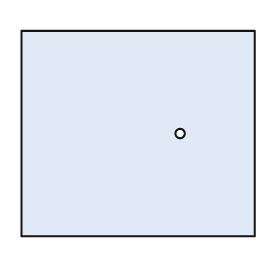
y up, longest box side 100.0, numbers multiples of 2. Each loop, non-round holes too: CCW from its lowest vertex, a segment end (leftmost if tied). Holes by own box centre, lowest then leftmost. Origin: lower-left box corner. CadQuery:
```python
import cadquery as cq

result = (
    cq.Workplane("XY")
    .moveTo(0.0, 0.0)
    .lineTo(100.0, 0.0)
    .lineTo(100.0, 88.0)
    .lineTo(0.0, 88.0)
    .close()
    .moveTo(68.0, 44.0)
    .circle(2.0)
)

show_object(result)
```